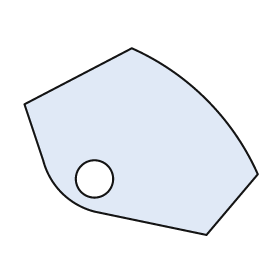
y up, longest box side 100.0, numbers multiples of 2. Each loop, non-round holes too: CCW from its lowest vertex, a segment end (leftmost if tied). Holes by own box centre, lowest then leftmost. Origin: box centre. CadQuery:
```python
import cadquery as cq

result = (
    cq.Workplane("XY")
    .moveTo(28.0, -40.0)
    .lineTo(50.0, -14.0)
    .threePointArc((28.0, 18.0), (-4.0, 40.0))
    .lineTo(-50.0, 16.0)
    .lineTo(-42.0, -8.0)
    .threePointArc((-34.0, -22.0), (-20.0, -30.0))
    .close()
    .moveTo(-20.0, -16.0)
    .circle(8.0)
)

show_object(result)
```